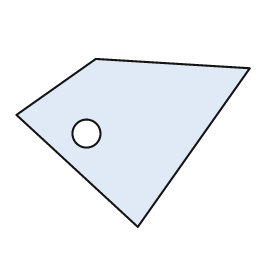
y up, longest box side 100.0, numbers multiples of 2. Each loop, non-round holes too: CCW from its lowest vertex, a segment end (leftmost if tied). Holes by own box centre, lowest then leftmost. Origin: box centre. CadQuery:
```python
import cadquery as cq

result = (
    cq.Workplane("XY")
    .moveTo(2.0, -36.0)
    .lineTo(50.0, 32.0)
    .lineTo(-16.0, 36.0)
    .lineTo(-50.0, 12.0)
    .close()
    .moveTo(-20.0, 4.0)
    .circle(6.0)
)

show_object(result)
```